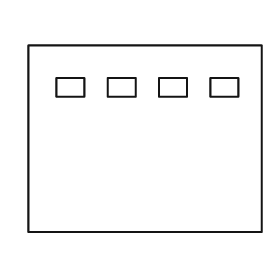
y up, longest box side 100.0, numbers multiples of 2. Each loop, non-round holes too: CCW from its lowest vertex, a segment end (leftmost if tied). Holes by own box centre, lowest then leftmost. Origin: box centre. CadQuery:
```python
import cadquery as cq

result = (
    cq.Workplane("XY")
    .moveTo(-50.0, -40.0)
    .lineTo(50.0, -40.0)
    .lineTo(50.0, 40.0)
    .lineTo(-50.0, 40.0)
    .close()
    .moveTo(-38.0, 18.0)
    .lineTo(-26.0, 18.0)
    .lineTo(-26.0, 26.0)
    .lineTo(-38.0, 26.0)
    .close()
    .moveTo(-16.0, 18.0)
    .lineTo(-4.0, 18.0)
    .lineTo(-4.0, 26.0)
    .lineTo(-16.0, 26.0)
    .close()
    .moveTo(6.0, 18.0)
    .lineTo(18.0, 18.0)
    .lineTo(18.0, 26.0)
    .lineTo(6.0, 26.0)
    .close()
    .moveTo(28.0, 18.0)
    .lineTo(40.0, 18.0)
    .lineTo(40.0, 26.0)
    .lineTo(28.0, 26.0)
    .close()
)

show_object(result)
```